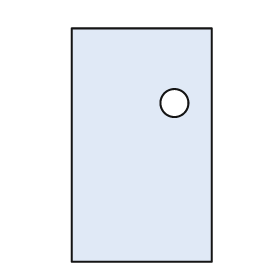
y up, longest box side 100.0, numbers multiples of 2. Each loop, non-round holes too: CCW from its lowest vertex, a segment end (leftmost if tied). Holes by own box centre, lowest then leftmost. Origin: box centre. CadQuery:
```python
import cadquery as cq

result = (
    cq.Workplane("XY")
    .moveTo(-30.0, -50.0)
    .lineTo(30.0, -50.0)
    .lineTo(30.0, 50.0)
    .lineTo(-30.0, 50.0)
    .close()
    .moveTo(14.0, 18.0)
    .circle(6.0)
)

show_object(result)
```